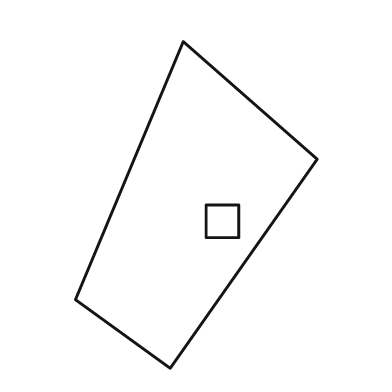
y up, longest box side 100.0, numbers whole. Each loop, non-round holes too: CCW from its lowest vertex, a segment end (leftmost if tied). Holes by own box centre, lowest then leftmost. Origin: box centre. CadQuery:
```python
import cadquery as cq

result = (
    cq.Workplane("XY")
    .moveTo(-8.0, -50.0)
    .lineTo(37.0, 14.0)
    .lineTo(-4.0, 50.0)
    .lineTo(-37.0, -29.0)
    .close()
    .moveTo(3.0, -10.0)
    .lineTo(13.0, -10.0)
    .lineTo(13.0, 0.0)
    .lineTo(3.0, 0.0)
    .close()
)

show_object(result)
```